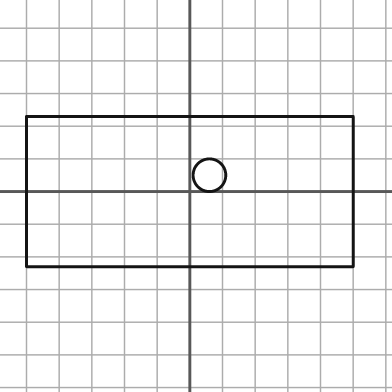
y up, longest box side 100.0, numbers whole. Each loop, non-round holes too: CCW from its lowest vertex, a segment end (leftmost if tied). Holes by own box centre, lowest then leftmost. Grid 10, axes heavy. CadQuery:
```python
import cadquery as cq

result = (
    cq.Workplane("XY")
    .moveTo(-50.0, -23.0)
    .lineTo(50.0, -23.0)
    .lineTo(50.0, 23.0)
    .lineTo(-50.0, 23.0)
    .close()
    .moveTo(6.0, 5.0)
    .circle(5.0)
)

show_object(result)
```